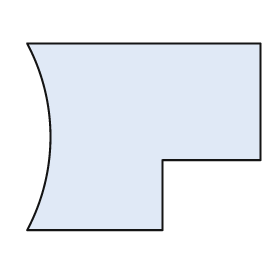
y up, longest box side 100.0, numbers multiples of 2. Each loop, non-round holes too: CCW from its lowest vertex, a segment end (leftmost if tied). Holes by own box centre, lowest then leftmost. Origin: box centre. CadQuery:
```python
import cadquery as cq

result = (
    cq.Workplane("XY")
    .moveTo(-50.0, -40.0)
    .lineTo(8.0, -40.0)
    .lineTo(8.0, -10.0)
    .lineTo(50.0, -10.0)
    .lineTo(50.0, 40.0)
    .lineTo(-50.0, 40.0)
    .threePointArc((-40.0, 0.0), (-50.0, -40.0))
    .close()
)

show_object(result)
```